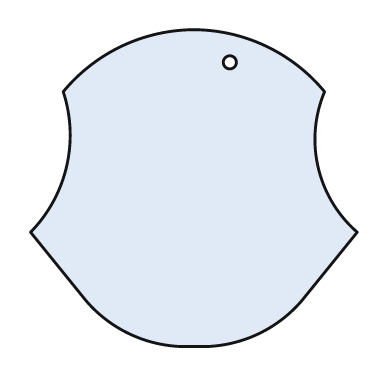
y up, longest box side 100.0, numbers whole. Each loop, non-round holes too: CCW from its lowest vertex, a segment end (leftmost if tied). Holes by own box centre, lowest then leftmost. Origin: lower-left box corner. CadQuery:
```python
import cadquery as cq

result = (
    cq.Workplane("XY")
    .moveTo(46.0, 0.0)
    .lineTo(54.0, 0.0)
    .threePointArc((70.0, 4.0), (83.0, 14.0))
    .lineTo(100.0, 35.0)
    .threePointArc((88.0, 55.0), (90.0, 78.0))
    .threePointArc((72.0, 92.0), (50.0, 97.0))
    .threePointArc((28.0, 92.0), (10.0, 78.0))
    .threePointArc((11.0, 55.0), (0.0, 35.0))
    .lineTo(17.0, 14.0)
    .threePointArc((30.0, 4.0), (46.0, 0.0))
    .close()
    .moveTo(61.0, 87.0)
    .circle(2.0)
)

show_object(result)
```